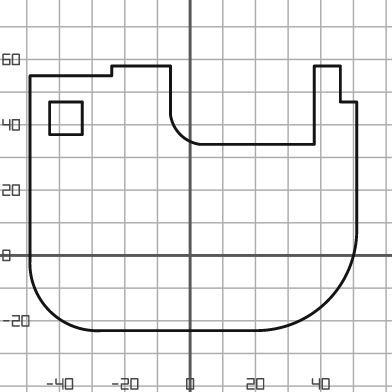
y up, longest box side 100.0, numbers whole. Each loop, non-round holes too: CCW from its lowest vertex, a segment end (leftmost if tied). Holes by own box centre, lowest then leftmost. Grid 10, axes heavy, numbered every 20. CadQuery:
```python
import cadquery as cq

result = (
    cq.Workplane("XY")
    .moveTo(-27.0, -23.0)
    .lineTo(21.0, -23.0)
    .threePointArc((42.0, -14.0), (51.0, 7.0))
    .lineTo(51.0, 47.0)
    .lineTo(46.0, 47.0)
    .lineTo(46.0, 58.0)
    .lineTo(38.0, 58.0)
    .lineTo(38.0, 34.0)
    .lineTo(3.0, 34.0)
    .threePointArc((-3.0, 37.0), (-6.0, 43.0))
    .lineTo(-6.0, 58.0)
    .lineTo(-24.0, 58.0)
    .lineTo(-24.0, 55.0)
    .lineTo(-49.0, 55.0)
    .lineTo(-49.0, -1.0)
    .threePointArc((-43.0, -17.0), (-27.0, -23.0))
    .close()
    .moveTo(-43.0, 37.0)
    .lineTo(-33.0, 37.0)
    .lineTo(-33.0, 47.0)
    .lineTo(-43.0, 47.0)
    .close()
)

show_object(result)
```